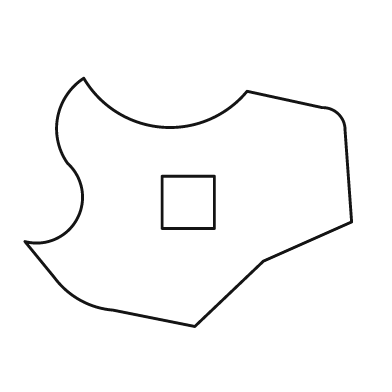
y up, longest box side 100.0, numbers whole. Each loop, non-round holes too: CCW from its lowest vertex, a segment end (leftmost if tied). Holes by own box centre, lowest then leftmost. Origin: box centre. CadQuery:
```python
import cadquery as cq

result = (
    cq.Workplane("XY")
    .moveTo(2.0, -38.0)
    .lineTo(23.0, -18.0)
    .lineTo(50.0, -6.0)
    .lineTo(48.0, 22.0)
    .threePointArc((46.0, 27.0), (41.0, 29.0))
    .lineTo(18.0, 34.0)
    .threePointArc((-8.0, 23.0), (-32.0, 38.0))
    .threePointArc((-40.0, 26.0), (-37.0, 12.0))
    .threePointArc((-34.0, -5.0), (-50.0, -12.0))
    .lineTo(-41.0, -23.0)
    .threePointArc((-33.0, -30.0), (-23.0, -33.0))
    .close()
    .moveTo(-8.0, -8.0)
    .lineTo(8.0, -8.0)
    .lineTo(8.0, 8.0)
    .lineTo(-8.0, 8.0)
    .close()
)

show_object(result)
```